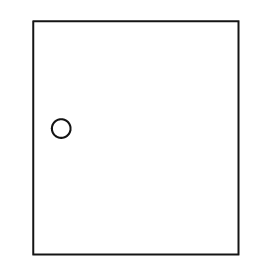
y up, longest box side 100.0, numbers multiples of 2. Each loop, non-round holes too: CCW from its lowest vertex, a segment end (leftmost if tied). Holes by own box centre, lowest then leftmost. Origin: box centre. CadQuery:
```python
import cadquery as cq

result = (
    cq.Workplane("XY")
    .moveTo(-44.0, -50.0)
    .lineTo(44.0, -50.0)
    .lineTo(44.0, 50.0)
    .lineTo(-44.0, 50.0)
    .close()
    .moveTo(-32.0, 4.0)
    .circle(4.0)
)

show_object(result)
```